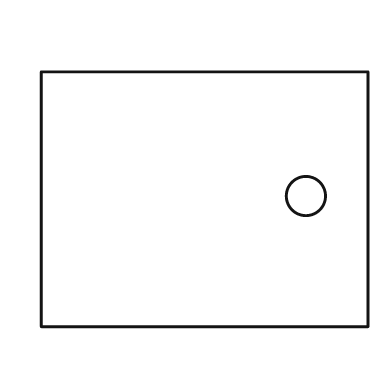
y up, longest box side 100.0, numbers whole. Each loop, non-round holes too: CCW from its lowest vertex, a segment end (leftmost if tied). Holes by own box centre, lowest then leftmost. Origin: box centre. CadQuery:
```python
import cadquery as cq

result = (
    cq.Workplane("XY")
    .moveTo(-50.0, -39.0)
    .lineTo(50.0, -39.0)
    .lineTo(50.0, 39.0)
    .lineTo(-50.0, 39.0)
    .close()
    .moveTo(31.0, 1.0)
    .circle(6.0)
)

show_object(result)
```